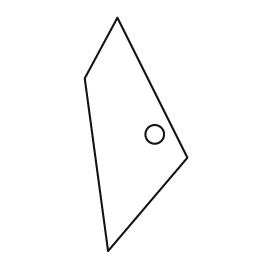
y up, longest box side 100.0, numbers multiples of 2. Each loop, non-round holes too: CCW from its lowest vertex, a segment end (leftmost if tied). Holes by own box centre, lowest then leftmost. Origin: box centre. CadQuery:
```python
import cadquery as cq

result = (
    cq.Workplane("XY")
    .moveTo(-12.0, -50.0)
    .lineTo(22.0, -10.0)
    .lineTo(-8.0, 50.0)
    .lineTo(-22.0, 24.0)
    .close()
    .moveTo(8.0, 0.0)
    .circle(4.0)
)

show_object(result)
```